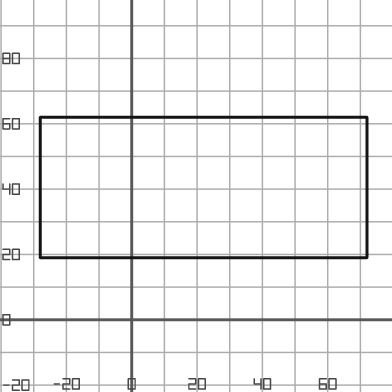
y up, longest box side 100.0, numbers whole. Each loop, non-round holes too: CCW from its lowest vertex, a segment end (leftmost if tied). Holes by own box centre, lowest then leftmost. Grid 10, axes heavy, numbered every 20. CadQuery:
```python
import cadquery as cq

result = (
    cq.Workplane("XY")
    .moveTo(-28.0, 19.0)
    .lineTo(72.0, 19.0)
    .lineTo(72.0, 62.0)
    .lineTo(-28.0, 62.0)
    .close()
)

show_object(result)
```